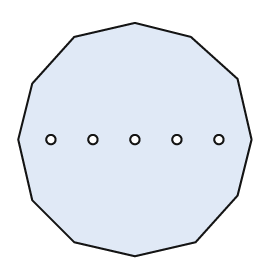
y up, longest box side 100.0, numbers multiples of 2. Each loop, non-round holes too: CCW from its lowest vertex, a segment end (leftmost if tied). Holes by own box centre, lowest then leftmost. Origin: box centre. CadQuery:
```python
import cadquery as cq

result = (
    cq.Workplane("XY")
    .moveTo(0.0, -50.0)
    .lineTo(26.0, -44.0)
    .lineTo(44.0, -24.0)
    .lineTo(50.0, 0.0)
    .lineTo(44.0, 26.0)
    .lineTo(24.0, 44.0)
    .lineTo(0.0, 50.0)
    .lineTo(-26.0, 44.0)
    .lineTo(-44.0, 24.0)
    .lineTo(-50.0, 0.0)
    .lineTo(-44.0, -26.0)
    .lineTo(-26.0, -44.0)
    .close()
    .moveTo(-36.0, 0.0)
    .circle(2.0)
    .moveTo(-18.0, 0.0)
    .circle(2.0)
    .moveTo(0.0, 0.0)
    .circle(2.0)
    .moveTo(18.0, 0.0)
    .circle(2.0)
    .moveTo(36.0, 0.0)
    .circle(2.0)
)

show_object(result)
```